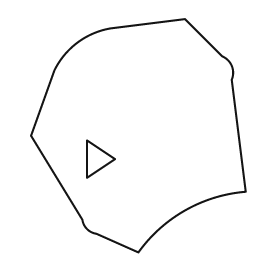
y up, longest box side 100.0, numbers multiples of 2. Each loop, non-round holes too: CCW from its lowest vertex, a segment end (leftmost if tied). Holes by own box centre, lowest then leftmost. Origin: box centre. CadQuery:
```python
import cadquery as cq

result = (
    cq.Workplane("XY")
    .moveTo(0.0, -50.0)
    .threePointArc((20.0, -32.0), (46.0, -24.0))
    .lineTo(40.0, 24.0)
    .threePointArc((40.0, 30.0), (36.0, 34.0))
    .lineTo(20.0, 50.0)
    .lineTo(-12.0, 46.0)
    .threePointArc((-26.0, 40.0), (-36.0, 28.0))
    .lineTo(-46.0, 0.0)
    .lineTo(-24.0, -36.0)
    .threePointArc((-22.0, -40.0), (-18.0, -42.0))
    .close()
    .moveTo(-22.0, -18.0)
    .lineTo(-10.0, -10.0)
    .lineTo(-22.0, -2.0)
    .close()
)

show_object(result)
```